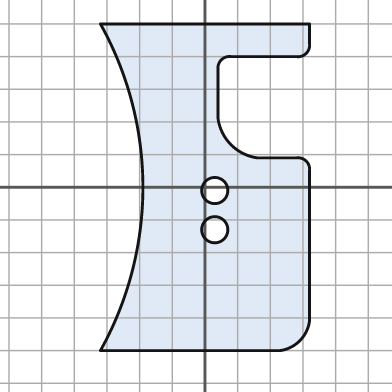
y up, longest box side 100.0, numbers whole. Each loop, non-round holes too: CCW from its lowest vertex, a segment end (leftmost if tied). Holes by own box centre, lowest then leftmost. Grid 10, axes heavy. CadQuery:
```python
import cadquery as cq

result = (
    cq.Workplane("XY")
    .moveTo(-32.0, -50.0)
    .lineTo(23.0, -50.0)
    .threePointArc((29.0, -47.0), (32.0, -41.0))
    .lineTo(32.0, 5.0)
    .threePointArc((31.0, 8.0), (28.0, 9.0))
    .lineTo(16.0, 9.0)
    .threePointArc((8.0, 13.0), (4.0, 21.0))
    .lineTo(4.0, 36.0)
    .threePointArc((5.0, 39.0), (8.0, 40.0))
    .lineTo(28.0, 40.0)
    .threePointArc((31.0, 41.0), (32.0, 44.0))
    .lineTo(32.0, 50.0)
    .lineTo(-32.0, 50.0)
    .threePointArc((-19.0, 0.0), (-32.0, -50.0))
    .close()
    .moveTo(3.0, -13.0)
    .circle(4.0)
    .moveTo(3.0, -1.0)
    .circle(4.0)
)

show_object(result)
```